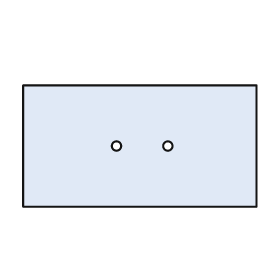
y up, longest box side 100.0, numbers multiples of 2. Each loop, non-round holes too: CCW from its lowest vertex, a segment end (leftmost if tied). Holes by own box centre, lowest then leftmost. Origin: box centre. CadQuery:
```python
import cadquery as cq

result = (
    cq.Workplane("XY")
    .moveTo(-50.0, -26.0)
    .lineTo(50.0, -26.0)
    .lineTo(50.0, 26.0)
    .lineTo(-50.0, 26.0)
    .close()
    .moveTo(-10.0, 0.0)
    .circle(2.0)
    .moveTo(12.0, 0.0)
    .circle(2.0)
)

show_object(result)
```